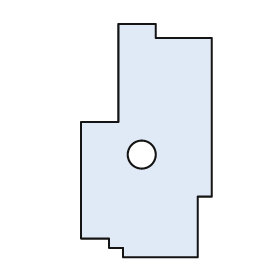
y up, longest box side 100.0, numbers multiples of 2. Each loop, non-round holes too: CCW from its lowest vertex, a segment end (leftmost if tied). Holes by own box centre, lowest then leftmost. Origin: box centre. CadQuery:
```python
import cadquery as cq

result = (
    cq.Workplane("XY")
    .moveTo(-10.0, -50.0)
    .lineTo(22.0, -50.0)
    .lineTo(22.0, -24.0)
    .lineTo(28.0, -24.0)
    .lineTo(28.0, 44.0)
    .lineTo(4.0, 44.0)
    .lineTo(4.0, 50.0)
    .lineTo(-12.0, 50.0)
    .lineTo(-12.0, 8.0)
    .lineTo(-28.0, 8.0)
    .lineTo(-28.0, -42.0)
    .lineTo(-16.0, -42.0)
    .lineTo(-16.0, -46.0)
    .lineTo(-10.0, -46.0)
    .close()
    .moveTo(-2.0, -6.0)
    .circle(6.0)
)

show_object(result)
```